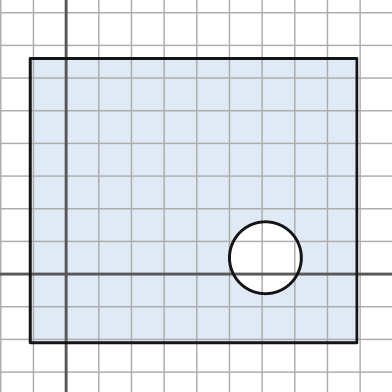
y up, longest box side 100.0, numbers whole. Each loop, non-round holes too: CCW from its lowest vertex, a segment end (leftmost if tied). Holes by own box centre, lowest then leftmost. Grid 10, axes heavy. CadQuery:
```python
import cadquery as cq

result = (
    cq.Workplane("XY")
    .moveTo(-11.0, -21.0)
    .lineTo(89.0, -21.0)
    .lineTo(89.0, 66.0)
    .lineTo(-11.0, 66.0)
    .close()
    .moveTo(61.0, 5.0)
    .circle(11.0)
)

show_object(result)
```